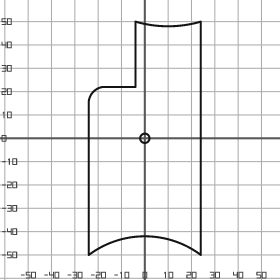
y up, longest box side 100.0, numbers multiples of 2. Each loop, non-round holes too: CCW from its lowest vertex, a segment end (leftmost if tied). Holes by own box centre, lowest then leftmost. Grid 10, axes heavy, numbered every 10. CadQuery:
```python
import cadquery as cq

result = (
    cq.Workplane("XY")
    .moveTo(-24.0, -50.0)
    .threePointArc((0.0, -42.0), (24.0, -50.0))
    .lineTo(24.0, 50.0)
    .threePointArc((10.0, 48.0), (-4.0, 50.0))
    .lineTo(-4.0, 22.0)
    .lineTo(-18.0, 22.0)
    .threePointArc((-22.0, 20.0), (-24.0, 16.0))
    .close()
    .moveTo(0.0, 0.0)
    .circle(2.0)
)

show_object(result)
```